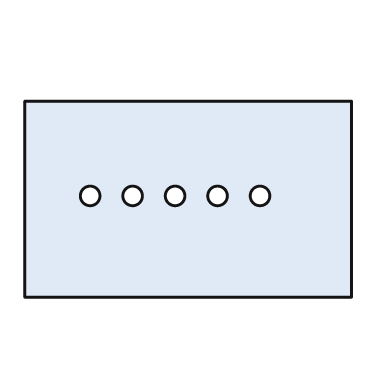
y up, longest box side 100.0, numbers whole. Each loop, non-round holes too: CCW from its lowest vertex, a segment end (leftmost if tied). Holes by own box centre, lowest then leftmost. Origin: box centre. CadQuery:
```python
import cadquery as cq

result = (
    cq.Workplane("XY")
    .moveTo(-50.0, -30.0)
    .lineTo(50.0, -30.0)
    .lineTo(50.0, 30.0)
    .lineTo(-50.0, 30.0)
    .close()
    .moveTo(-30.0, 1.0)
    .circle(3.0)
    .moveTo(-17.0, 1.0)
    .circle(3.0)
    .moveTo(-4.0, 1.0)
    .circle(3.0)
    .moveTo(9.0, 1.0)
    .circle(3.0)
    .moveTo(22.0, 1.0)
    .circle(3.0)
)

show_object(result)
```